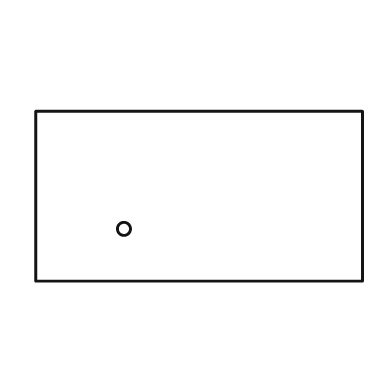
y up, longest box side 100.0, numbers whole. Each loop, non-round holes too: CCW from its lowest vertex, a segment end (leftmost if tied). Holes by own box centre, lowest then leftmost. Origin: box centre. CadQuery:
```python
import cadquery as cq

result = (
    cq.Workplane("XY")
    .moveTo(-50.0, -26.0)
    .lineTo(50.0, -26.0)
    .lineTo(50.0, 26.0)
    .lineTo(-50.0, 26.0)
    .close()
    .moveTo(-23.0, -10.0)
    .circle(2.0)
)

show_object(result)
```